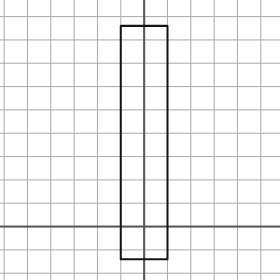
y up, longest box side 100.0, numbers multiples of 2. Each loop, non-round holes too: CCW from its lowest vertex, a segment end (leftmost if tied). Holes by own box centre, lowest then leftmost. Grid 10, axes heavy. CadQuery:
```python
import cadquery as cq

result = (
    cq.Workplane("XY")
    .moveTo(-10.0, -14.0)
    .lineTo(10.0, -14.0)
    .lineTo(10.0, 86.0)
    .lineTo(-10.0, 86.0)
    .close()
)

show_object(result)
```